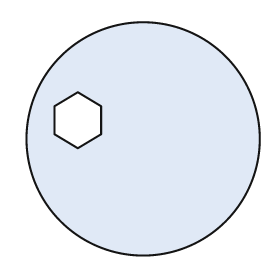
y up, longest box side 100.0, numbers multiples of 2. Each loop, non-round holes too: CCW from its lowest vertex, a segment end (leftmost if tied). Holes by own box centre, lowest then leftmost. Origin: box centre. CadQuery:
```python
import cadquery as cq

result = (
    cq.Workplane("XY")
    .moveTo(0.0, 0.0)
    .circle(50.0)
    .moveTo(-28.0, -4.0)
    .lineTo(-18.0, 2.0)
    .lineTo(-18.0, 14.0)
    .lineTo(-28.0, 20.0)
    .lineTo(-38.0, 14.0)
    .lineTo(-38.0, 2.0)
    .close()
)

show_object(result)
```